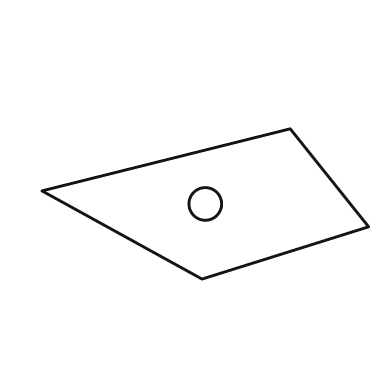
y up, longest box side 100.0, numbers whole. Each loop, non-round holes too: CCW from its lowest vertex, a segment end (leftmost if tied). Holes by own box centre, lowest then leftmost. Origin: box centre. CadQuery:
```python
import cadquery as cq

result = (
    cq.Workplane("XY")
    .moveTo(-1.0, -23.0)
    .lineTo(50.0, -7.0)
    .lineTo(26.0, 23.0)
    .lineTo(-50.0, 4.0)
    .close()
    .moveTo(0.0, 0.0)
    .circle(5.0)
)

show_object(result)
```